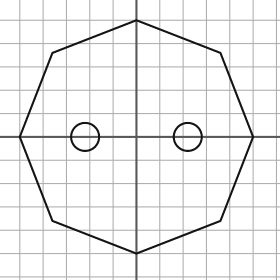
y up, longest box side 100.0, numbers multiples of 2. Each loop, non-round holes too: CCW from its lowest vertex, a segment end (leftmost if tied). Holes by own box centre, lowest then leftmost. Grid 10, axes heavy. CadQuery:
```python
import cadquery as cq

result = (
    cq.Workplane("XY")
    .moveTo(0.0, -50.0)
    .lineTo(36.0, -36.0)
    .lineTo(50.0, 0.0)
    .lineTo(36.0, 36.0)
    .lineTo(0.0, 50.0)
    .lineTo(-36.0, 36.0)
    .lineTo(-50.0, 0.0)
    .lineTo(-36.0, -36.0)
    .close()
    .moveTo(-22.0, 0.0)
    .circle(6.0)
    .moveTo(22.0, 0.0)
    .circle(6.0)
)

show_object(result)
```